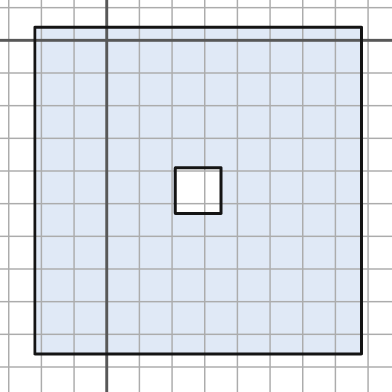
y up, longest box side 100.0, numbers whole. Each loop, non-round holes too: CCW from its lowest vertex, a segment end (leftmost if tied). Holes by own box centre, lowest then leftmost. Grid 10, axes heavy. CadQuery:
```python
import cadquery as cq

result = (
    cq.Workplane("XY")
    .moveTo(-22.0, -96.0)
    .lineTo(78.0, -96.0)
    .lineTo(78.0, 4.0)
    .lineTo(-22.0, 4.0)
    .close()
    .moveTo(21.0, -53.0)
    .lineTo(35.0, -53.0)
    .lineTo(35.0, -39.0)
    .lineTo(21.0, -39.0)
    .close()
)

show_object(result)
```